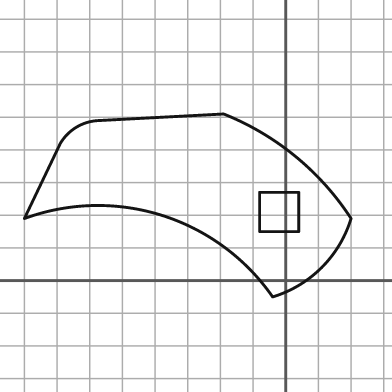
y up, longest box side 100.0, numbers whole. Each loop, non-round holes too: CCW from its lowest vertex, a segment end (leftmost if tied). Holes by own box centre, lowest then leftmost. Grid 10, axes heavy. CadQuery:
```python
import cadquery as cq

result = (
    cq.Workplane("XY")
    .moveTo(-4.0, -5.0)
    .threePointArc((11.0, 4.0), (20.0, 19.0))
    .threePointArc((3.0, 38.0), (-19.0, 51.0))
    .lineTo(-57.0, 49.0)
    .threePointArc((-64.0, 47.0), (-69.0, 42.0))
    .lineTo(-80.0, 19.0)
    .threePointArc((-38.0, 20.0), (-4.0, -5.0))
    .close()
    .moveTo(-8.0, 15.0)
    .lineTo(4.0, 15.0)
    .lineTo(4.0, 27.0)
    .lineTo(-8.0, 27.0)
    .close()
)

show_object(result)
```